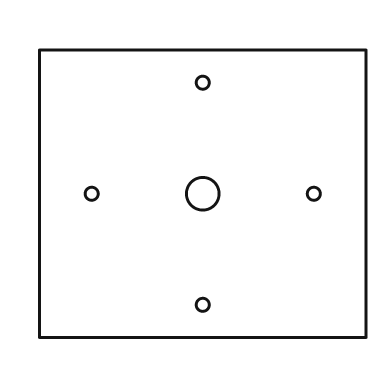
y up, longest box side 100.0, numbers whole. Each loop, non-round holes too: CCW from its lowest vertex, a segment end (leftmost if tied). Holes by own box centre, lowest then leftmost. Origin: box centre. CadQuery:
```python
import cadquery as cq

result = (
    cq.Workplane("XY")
    .moveTo(-50.0, -44.0)
    .lineTo(50.0, -44.0)
    .lineTo(50.0, 44.0)
    .lineTo(-50.0, 44.0)
    .close()
    .moveTo(0.0, -34.0)
    .circle(2.0)
    .moveTo(-34.0, 0.0)
    .circle(2.0)
    .moveTo(0.0, 0.0)
    .circle(5.0)
    .moveTo(34.0, 0.0)
    .circle(2.0)
    .moveTo(0.0, 34.0)
    .circle(2.0)
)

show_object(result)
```